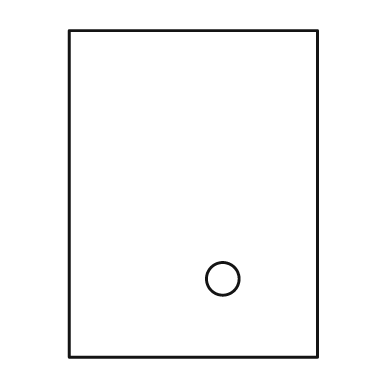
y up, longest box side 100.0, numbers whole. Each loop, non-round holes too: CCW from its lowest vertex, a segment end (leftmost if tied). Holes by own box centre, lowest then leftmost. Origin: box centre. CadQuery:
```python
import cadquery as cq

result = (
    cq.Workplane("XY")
    .moveTo(-38.0, -50.0)
    .lineTo(38.0, -50.0)
    .lineTo(38.0, 50.0)
    .lineTo(-38.0, 50.0)
    .close()
    .moveTo(9.0, -26.0)
    .circle(5.0)
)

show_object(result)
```